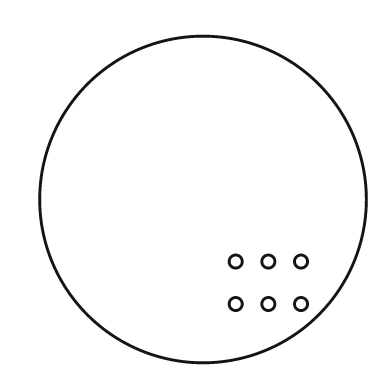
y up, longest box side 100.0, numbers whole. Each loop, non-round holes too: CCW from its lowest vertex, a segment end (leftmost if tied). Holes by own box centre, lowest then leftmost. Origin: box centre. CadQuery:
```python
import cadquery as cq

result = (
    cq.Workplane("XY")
    .moveTo(0.0, 0.0)
    .circle(50.0)
    .moveTo(10.0, -32.0)
    .circle(2.0)
    .moveTo(20.0, -32.0)
    .circle(2.0)
    .moveTo(30.0, -32.0)
    .circle(2.0)
    .moveTo(10.0, -19.0)
    .circle(2.0)
    .moveTo(20.0, -19.0)
    .circle(2.0)
    .moveTo(30.0, -19.0)
    .circle(2.0)
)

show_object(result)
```